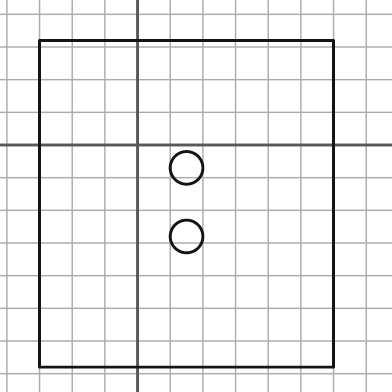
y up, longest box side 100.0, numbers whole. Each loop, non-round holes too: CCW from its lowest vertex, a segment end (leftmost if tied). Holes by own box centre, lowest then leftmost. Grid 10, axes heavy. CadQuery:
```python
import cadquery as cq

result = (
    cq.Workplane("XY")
    .moveTo(-30.0, -68.0)
    .lineTo(60.0, -68.0)
    .lineTo(60.0, 32.0)
    .lineTo(-30.0, 32.0)
    .close()
    .moveTo(15.0, -28.0)
    .circle(5.0)
    .moveTo(15.0, -7.0)
    .circle(5.0)
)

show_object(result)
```